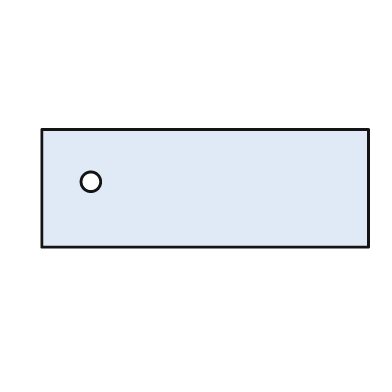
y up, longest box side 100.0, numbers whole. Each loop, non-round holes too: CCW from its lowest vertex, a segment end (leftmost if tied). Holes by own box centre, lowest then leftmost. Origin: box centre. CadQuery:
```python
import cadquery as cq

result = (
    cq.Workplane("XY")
    .moveTo(-50.0, -18.0)
    .lineTo(50.0, -18.0)
    .lineTo(50.0, 18.0)
    .lineTo(-50.0, 18.0)
    .close()
    .moveTo(-35.0, 2.0)
    .circle(3.0)
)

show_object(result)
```